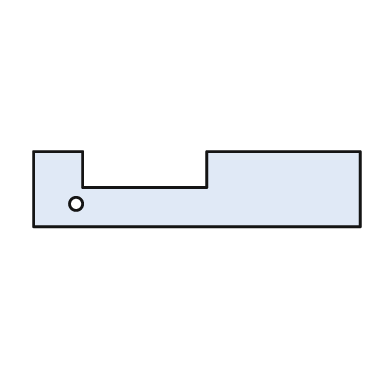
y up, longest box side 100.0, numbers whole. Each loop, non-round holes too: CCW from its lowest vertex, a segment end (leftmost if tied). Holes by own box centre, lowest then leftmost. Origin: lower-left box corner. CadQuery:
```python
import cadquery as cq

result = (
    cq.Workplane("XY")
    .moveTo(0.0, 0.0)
    .lineTo(100.0, 0.0)
    .lineTo(100.0, 23.0)
    .lineTo(53.0, 23.0)
    .lineTo(53.0, 12.0)
    .lineTo(15.0, 12.0)
    .lineTo(15.0, 23.0)
    .lineTo(0.0, 23.0)
    .close()
    .moveTo(13.0, 7.0)
    .circle(2.0)
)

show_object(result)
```